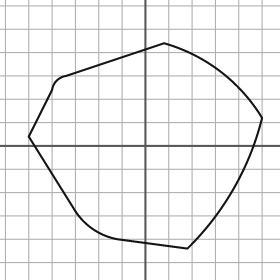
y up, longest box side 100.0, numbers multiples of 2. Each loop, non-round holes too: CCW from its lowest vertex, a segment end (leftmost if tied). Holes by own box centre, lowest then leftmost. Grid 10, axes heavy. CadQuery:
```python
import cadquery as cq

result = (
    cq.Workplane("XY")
    .moveTo(18.0, -44.0)
    .threePointArc((38.0, -18.0), (50.0, 12.0))
    .threePointArc((32.0, 32.0), (8.0, 44.0))
    .lineTo(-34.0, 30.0)
    .threePointArc((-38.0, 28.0), (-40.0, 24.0))
    .lineTo(-50.0, 4.0)
    .lineTo(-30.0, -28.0)
    .threePointArc((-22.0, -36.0), (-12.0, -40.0))
    .close()
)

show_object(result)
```